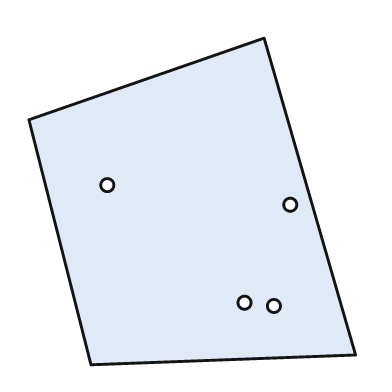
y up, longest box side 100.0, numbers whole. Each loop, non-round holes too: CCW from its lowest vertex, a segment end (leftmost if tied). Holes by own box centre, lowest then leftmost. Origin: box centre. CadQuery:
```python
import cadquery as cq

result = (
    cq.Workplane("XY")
    .moveTo(-31.0, -50.0)
    .lineTo(50.0, -47.0)
    .lineTo(22.0, 50.0)
    .lineTo(-50.0, 25.0)
    .close()
    .moveTo(25.0, -32.0)
    .circle(2.0)
    .moveTo(16.0, -31.0)
    .circle(2.0)
    .moveTo(30.0, -1.0)
    .circle(2.0)
    .moveTo(-26.0, 5.0)
    .circle(2.0)
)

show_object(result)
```